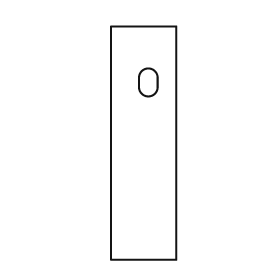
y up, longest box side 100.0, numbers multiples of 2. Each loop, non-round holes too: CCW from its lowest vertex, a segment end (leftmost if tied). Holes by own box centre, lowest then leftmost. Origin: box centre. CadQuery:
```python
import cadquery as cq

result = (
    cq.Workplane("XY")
    .moveTo(-14.0, -50.0)
    .lineTo(14.0, -50.0)
    .lineTo(14.0, 50.0)
    .lineTo(-14.0, 50.0)
    .close()
    .moveTo(-2.0, 24.0)
    .threePointArc((2.0, 20.0), (6.0, 24.0))
    .lineTo(6.0, 28.0)
    .threePointArc((2.0, 32.0), (-2.0, 28.0))
    .close()
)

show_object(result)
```